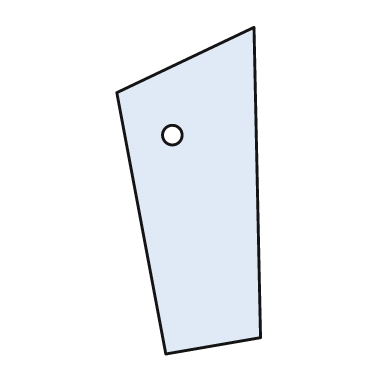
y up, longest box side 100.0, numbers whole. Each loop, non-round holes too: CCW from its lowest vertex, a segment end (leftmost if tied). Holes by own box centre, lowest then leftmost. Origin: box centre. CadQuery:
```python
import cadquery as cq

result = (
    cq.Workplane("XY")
    .moveTo(-7.0, -50.0)
    .lineTo(22.0, -45.0)
    .lineTo(20.0, 50.0)
    .lineTo(-22.0, 30.0)
    .close()
    .moveTo(-5.0, 17.0)
    .circle(3.0)
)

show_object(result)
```